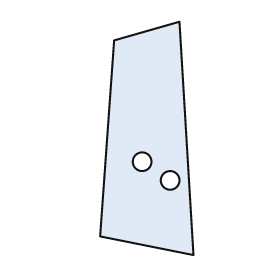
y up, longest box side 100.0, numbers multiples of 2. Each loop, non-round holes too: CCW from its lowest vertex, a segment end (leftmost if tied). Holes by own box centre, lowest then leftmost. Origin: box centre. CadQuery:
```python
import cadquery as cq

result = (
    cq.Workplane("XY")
    .moveTo(20.0, -50.0)
    .lineTo(14.0, 50.0)
    .lineTo(-14.0, 42.0)
    .lineTo(-20.0, -42.0)
    .close()
    .moveTo(10.0, -18.0)
    .circle(4.0)
    .moveTo(-2.0, -10.0)
    .circle(4.0)
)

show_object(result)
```